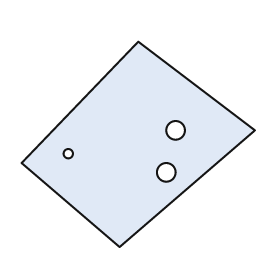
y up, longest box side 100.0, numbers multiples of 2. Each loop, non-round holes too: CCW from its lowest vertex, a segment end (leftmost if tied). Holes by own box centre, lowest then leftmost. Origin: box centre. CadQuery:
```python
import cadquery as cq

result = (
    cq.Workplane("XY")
    .moveTo(-8.0, -44.0)
    .lineTo(50.0, 6.0)
    .lineTo(0.0, 44.0)
    .lineTo(-50.0, -8.0)
    .close()
    .moveTo(12.0, -12.0)
    .circle(4.0)
    .moveTo(-30.0, -4.0)
    .circle(2.0)
    .moveTo(16.0, 6.0)
    .circle(4.0)
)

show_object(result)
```